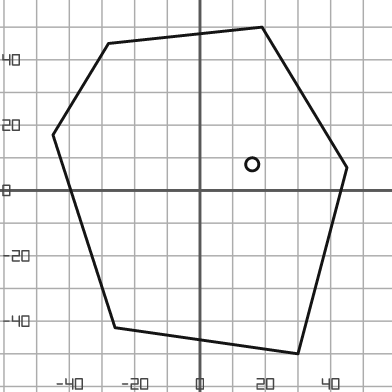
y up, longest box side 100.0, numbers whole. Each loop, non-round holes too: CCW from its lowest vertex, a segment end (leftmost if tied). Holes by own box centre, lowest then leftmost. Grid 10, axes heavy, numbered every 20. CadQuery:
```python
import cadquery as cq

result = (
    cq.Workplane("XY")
    .moveTo(30.0, -50.0)
    .lineTo(45.0, 7.0)
    .lineTo(19.0, 50.0)
    .lineTo(-28.0, 45.0)
    .lineTo(-45.0, 17.0)
    .lineTo(-26.0, -42.0)
    .close()
    .moveTo(16.0, 8.0)
    .circle(2.0)
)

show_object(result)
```